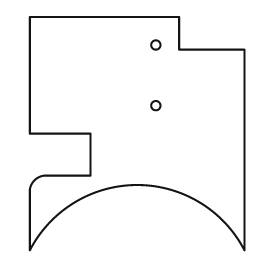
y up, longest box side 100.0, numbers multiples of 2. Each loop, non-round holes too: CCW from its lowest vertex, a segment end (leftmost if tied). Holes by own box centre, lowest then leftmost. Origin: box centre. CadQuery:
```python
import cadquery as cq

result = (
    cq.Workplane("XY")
    .moveTo(-46.0, -50.0)
    .threePointArc((0.0, -22.0), (46.0, -50.0))
    .lineTo(46.0, 36.0)
    .lineTo(18.0, 36.0)
    .lineTo(18.0, 50.0)
    .lineTo(-46.0, 50.0)
    .lineTo(-46.0, 0.0)
    .lineTo(-20.0, 0.0)
    .lineTo(-20.0, -18.0)
    .lineTo(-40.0, -18.0)
    .threePointArc((-44.0, -20.0), (-46.0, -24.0))
    .close()
    .moveTo(8.0, 12.0)
    .circle(2.0)
    .moveTo(8.0, 38.0)
    .circle(2.0)
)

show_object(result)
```